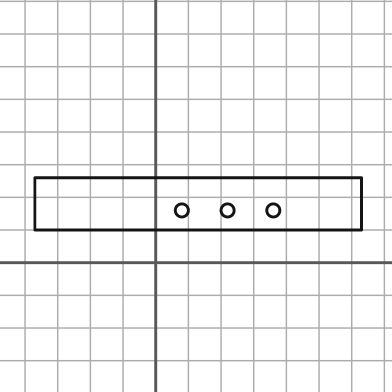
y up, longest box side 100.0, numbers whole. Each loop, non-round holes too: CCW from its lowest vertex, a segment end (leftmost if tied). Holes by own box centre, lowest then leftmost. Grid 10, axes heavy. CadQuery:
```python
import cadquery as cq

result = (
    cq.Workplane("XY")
    .moveTo(-37.0, 10.0)
    .lineTo(63.0, 10.0)
    .lineTo(63.0, 26.0)
    .lineTo(-37.0, 26.0)
    .close()
    .moveTo(8.0, 16.0)
    .circle(2.0)
    .moveTo(22.0, 16.0)
    .circle(2.0)
    .moveTo(36.0, 16.0)
    .circle(2.0)
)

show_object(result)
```